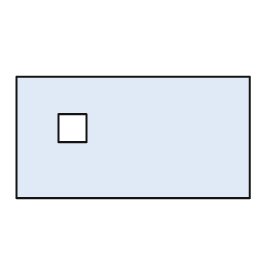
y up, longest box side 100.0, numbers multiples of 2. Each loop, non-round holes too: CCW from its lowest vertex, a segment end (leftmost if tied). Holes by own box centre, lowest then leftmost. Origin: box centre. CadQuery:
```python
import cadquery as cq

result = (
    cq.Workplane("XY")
    .moveTo(-50.0, -26.0)
    .lineTo(50.0, -26.0)
    .lineTo(50.0, 26.0)
    .lineTo(-50.0, 26.0)
    .close()
    .moveTo(-32.0, -2.0)
    .lineTo(-20.0, -2.0)
    .lineTo(-20.0, 10.0)
    .lineTo(-32.0, 10.0)
    .close()
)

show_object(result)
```